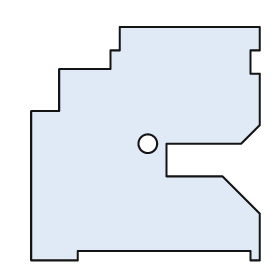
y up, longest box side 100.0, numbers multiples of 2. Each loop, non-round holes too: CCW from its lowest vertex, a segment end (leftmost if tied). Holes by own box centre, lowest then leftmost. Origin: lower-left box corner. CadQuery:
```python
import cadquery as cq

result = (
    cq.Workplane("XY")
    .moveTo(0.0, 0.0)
    .lineTo(20.0, 0.0)
    .lineTo(20.0, 4.0)
    .lineTo(94.0, 4.0)
    .lineTo(94.0, 0.0)
    .lineTo(98.0, 0.0)
    .lineTo(98.0, 20.0)
    .lineTo(82.0, 36.0)
    .lineTo(58.0, 36.0)
    .lineTo(58.0, 50.0)
    .lineTo(90.0, 50.0)
    .lineTo(98.0, 58.0)
    .lineTo(98.0, 80.0)
    .lineTo(94.0, 80.0)
    .lineTo(94.0, 90.0)
    .lineTo(98.0, 90.0)
    .lineTo(98.0, 100.0)
    .lineTo(38.0, 100.0)
    .lineTo(38.0, 90.0)
    .lineTo(34.0, 90.0)
    .lineTo(34.0, 82.0)
    .lineTo(12.0, 82.0)
    .lineTo(12.0, 64.0)
    .lineTo(0.0, 64.0)
    .close()
    .moveTo(50.0, 50.0)
    .circle(4.0)
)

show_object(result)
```